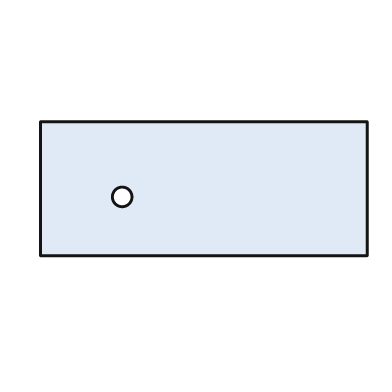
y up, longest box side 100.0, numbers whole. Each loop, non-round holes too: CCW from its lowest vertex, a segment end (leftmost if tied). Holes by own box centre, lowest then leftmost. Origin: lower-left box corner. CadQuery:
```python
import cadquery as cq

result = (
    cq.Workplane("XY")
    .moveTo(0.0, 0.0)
    .lineTo(100.0, 0.0)
    .lineTo(100.0, 41.0)
    .lineTo(0.0, 41.0)
    .close()
    .moveTo(25.0, 18.0)
    .circle(3.0)
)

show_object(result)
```